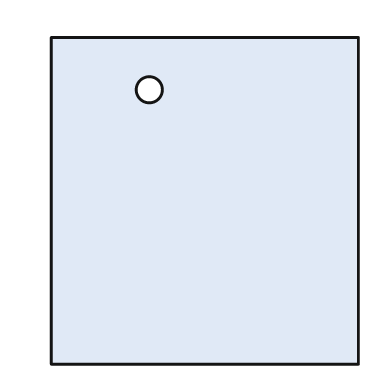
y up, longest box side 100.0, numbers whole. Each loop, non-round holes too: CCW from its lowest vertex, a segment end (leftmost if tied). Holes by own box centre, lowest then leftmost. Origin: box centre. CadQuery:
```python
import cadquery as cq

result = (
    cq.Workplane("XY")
    .moveTo(-47.0, -50.0)
    .lineTo(47.0, -50.0)
    .lineTo(47.0, 50.0)
    .lineTo(-47.0, 50.0)
    .close()
    .moveTo(-17.0, 34.0)
    .circle(4.0)
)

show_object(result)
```